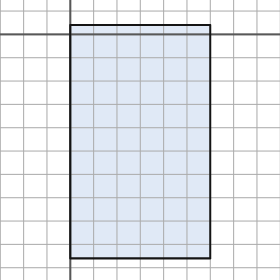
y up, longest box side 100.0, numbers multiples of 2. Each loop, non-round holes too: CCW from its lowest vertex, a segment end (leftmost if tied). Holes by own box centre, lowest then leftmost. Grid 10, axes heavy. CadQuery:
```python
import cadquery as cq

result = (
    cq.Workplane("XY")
    .moveTo(0.0, -96.0)
    .lineTo(60.0, -96.0)
    .lineTo(60.0, 4.0)
    .lineTo(0.0, 4.0)
    .close()
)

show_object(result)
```